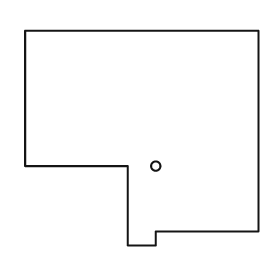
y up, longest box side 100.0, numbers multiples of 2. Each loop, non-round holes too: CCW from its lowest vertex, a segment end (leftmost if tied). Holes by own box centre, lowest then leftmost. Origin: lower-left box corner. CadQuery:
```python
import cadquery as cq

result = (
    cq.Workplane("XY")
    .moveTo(44.0, 0.0)
    .lineTo(56.0, 0.0)
    .lineTo(56.0, 6.0)
    .lineTo(100.0, 6.0)
    .lineTo(100.0, 92.0)
    .lineTo(0.0, 92.0)
    .lineTo(0.0, 34.0)
    .lineTo(44.0, 34.0)
    .close()
    .moveTo(56.0, 34.0)
    .circle(2.0)
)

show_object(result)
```